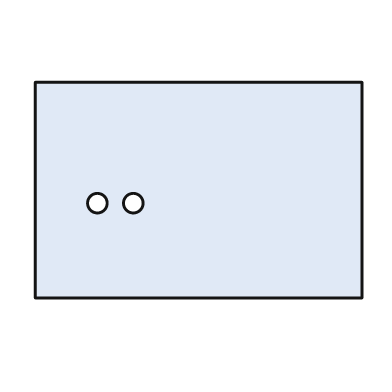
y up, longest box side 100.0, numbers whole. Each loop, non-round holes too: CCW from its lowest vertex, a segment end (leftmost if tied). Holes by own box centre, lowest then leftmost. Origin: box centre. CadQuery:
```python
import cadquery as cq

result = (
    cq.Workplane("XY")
    .moveTo(-50.0, -33.0)
    .lineTo(50.0, -33.0)
    .lineTo(50.0, 33.0)
    .lineTo(-50.0, 33.0)
    .close()
    .moveTo(-31.0, -4.0)
    .circle(3.0)
    .moveTo(-20.0, -4.0)
    .circle(3.0)
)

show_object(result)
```